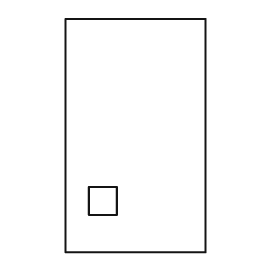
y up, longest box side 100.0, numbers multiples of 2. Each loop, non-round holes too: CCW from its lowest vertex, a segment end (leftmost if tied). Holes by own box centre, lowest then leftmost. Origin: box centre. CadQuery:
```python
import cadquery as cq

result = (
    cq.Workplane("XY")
    .moveTo(-30.0, -50.0)
    .lineTo(30.0, -50.0)
    .lineTo(30.0, 50.0)
    .lineTo(-30.0, 50.0)
    .close()
    .moveTo(-20.0, -34.0)
    .lineTo(-8.0, -34.0)
    .lineTo(-8.0, -22.0)
    .lineTo(-20.0, -22.0)
    .close()
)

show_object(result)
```